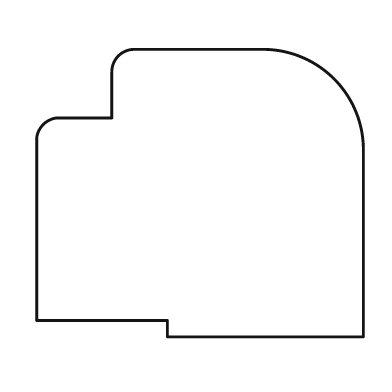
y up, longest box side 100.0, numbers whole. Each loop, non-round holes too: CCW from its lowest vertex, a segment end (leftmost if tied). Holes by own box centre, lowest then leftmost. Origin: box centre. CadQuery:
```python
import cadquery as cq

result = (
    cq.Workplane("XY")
    .moveTo(-10.0, -44.0)
    .lineTo(50.0, -44.0)
    .lineTo(50.0, 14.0)
    .threePointArc((41.0, 35.0), (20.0, 44.0))
    .lineTo(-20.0, 44.0)
    .threePointArc((-25.0, 42.0), (-27.0, 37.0))
    .lineTo(-27.0, 23.0)
    .lineTo(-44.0, 23.0)
    .threePointArc((-48.0, 21.0), (-50.0, 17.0))
    .lineTo(-50.0, -39.0)
    .lineTo(-10.0, -39.0)
    .close()
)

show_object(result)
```